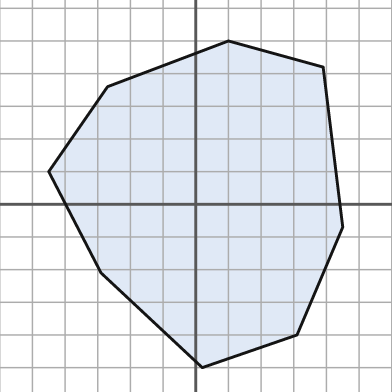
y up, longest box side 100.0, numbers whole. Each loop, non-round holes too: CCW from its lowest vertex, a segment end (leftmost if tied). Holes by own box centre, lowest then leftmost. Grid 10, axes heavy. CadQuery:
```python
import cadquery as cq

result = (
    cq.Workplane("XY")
    .moveTo(2.0, -50.0)
    .lineTo(31.0, -40.0)
    .lineTo(45.0, -7.0)
    .lineTo(39.0, 42.0)
    .lineTo(10.0, 50.0)
    .lineTo(-27.0, 36.0)
    .lineTo(-45.0, 10.0)
    .lineTo(-29.0, -21.0)
    .close()
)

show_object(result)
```